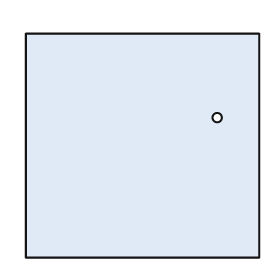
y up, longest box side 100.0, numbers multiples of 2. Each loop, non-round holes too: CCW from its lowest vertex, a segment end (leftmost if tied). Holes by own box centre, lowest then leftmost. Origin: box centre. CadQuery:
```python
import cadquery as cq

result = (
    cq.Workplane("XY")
    .moveTo(-50.0, -48.0)
    .lineTo(50.0, -48.0)
    .lineTo(50.0, 48.0)
    .lineTo(-50.0, 48.0)
    .close()
    .moveTo(32.0, 12.0)
    .circle(2.0)
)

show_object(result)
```